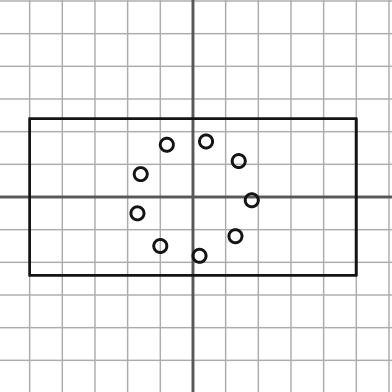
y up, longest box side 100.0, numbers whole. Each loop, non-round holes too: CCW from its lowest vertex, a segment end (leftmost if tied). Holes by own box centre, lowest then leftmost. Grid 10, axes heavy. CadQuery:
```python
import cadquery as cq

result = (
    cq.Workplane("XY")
    .moveTo(-50.0, -24.0)
    .lineTo(50.0, -24.0)
    .lineTo(50.0, 24.0)
    .lineTo(-50.0, 24.0)
    .close()
    .moveTo(2.0, -18.0)
    .circle(2.0)
    .moveTo(-10.0, -15.0)
    .circle(2.0)
    .moveTo(13.0, -12.0)
    .circle(2.0)
    .moveTo(-17.0, -5.0)
    .circle(2.0)
    .moveTo(18.0, -1.0)
    .circle(2.0)
    .moveTo(-16.0, 7.0)
    .circle(2.0)
    .moveTo(14.0, 11.0)
    .circle(2.0)
    .moveTo(-8.0, 16.0)
    .circle(2.0)
    .moveTo(4.0, 17.0)
    .circle(2.0)
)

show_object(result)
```